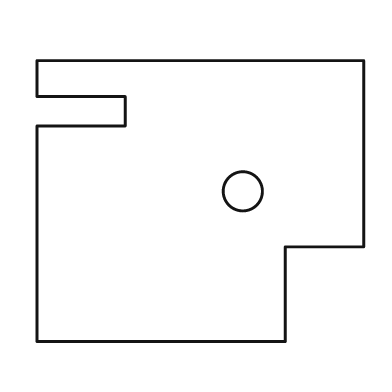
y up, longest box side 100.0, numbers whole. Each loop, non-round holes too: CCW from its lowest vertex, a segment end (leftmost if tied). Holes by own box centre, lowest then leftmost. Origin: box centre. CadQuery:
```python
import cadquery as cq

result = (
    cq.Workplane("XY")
    .moveTo(-50.0, -43.0)
    .lineTo(26.0, -43.0)
    .lineTo(26.0, -14.0)
    .lineTo(50.0, -14.0)
    .lineTo(50.0, 43.0)
    .lineTo(-50.0, 43.0)
    .lineTo(-50.0, 32.0)
    .lineTo(-23.0, 32.0)
    .lineTo(-23.0, 23.0)
    .lineTo(-50.0, 23.0)
    .close()
    .moveTo(13.0, 3.0)
    .circle(6.0)
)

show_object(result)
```